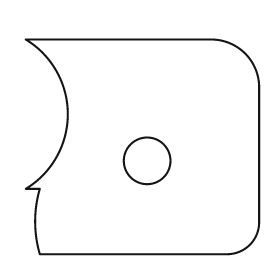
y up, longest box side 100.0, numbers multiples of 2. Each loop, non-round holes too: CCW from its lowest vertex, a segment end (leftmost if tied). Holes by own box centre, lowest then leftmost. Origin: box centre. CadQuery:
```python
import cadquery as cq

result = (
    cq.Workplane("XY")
    .moveTo(-44.0, -46.0)
    .lineTo(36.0, -46.0)
    .threePointArc((46.0, -42.0), (50.0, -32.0))
    .lineTo(50.0, 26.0)
    .threePointArc((44.0, 40.0), (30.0, 46.0))
    .lineTo(-50.0, 46.0)
    .threePointArc((-32.0, 14.0), (-50.0, -18.0))
    .lineTo(-44.0, -18.0)
    .threePointArc((-46.0, -32.0), (-44.0, -46.0))
    .close()
    .moveTo(2.0, -6.0)
    .circle(10.0)
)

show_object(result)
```